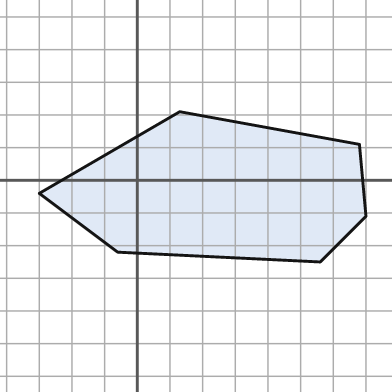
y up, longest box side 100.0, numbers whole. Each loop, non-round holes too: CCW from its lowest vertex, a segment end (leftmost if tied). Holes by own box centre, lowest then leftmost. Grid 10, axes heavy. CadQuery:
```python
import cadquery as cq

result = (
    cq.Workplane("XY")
    .moveTo(56.0, -25.0)
    .lineTo(70.0, -11.0)
    .lineTo(68.0, 11.0)
    .lineTo(13.0, 21.0)
    .lineTo(-30.0, -4.0)
    .lineTo(-6.0, -22.0)
    .close()
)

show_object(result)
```